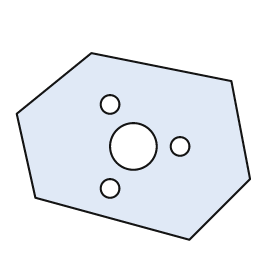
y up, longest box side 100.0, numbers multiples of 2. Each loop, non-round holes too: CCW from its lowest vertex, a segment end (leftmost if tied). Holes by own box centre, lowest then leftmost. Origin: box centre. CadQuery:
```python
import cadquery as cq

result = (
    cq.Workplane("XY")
    .moveTo(24.0, -40.0)
    .lineTo(50.0, -14.0)
    .lineTo(42.0, 28.0)
    .lineTo(-18.0, 40.0)
    .lineTo(-50.0, 14.0)
    .lineTo(-42.0, -22.0)
    .close()
    .moveTo(-10.0, -18.0)
    .circle(4.0)
    .moveTo(0.0, 0.0)
    .circle(10.0)
    .moveTo(20.0, 0.0)
    .circle(4.0)
    .moveTo(-10.0, 18.0)
    .circle(4.0)
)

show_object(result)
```